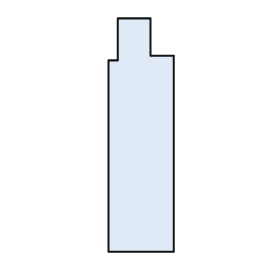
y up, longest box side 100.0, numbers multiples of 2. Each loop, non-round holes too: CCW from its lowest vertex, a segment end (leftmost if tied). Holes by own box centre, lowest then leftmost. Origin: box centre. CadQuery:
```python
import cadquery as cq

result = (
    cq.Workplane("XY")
    .moveTo(-14.0, -50.0)
    .lineTo(14.0, -50.0)
    .lineTo(14.0, 34.0)
    .lineTo(4.0, 34.0)
    .lineTo(4.0, 50.0)
    .lineTo(-10.0, 50.0)
    .lineTo(-10.0, 32.0)
    .lineTo(-14.0, 32.0)
    .close()
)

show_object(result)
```